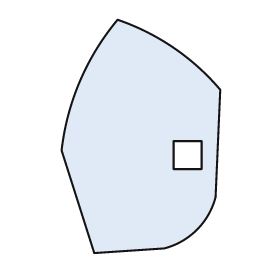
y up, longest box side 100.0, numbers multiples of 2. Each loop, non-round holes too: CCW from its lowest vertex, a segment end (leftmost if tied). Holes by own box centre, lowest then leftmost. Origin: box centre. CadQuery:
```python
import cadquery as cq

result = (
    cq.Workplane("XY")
    .moveTo(-20.0, -50.0)
    .lineTo(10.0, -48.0)
    .threePointArc((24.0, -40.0), (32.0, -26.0))
    .lineTo(34.0, 20.0)
    .threePointArc((14.0, 38.0), (-10.0, 50.0))
    .threePointArc((-26.0, 24.0), (-34.0, -6.0))
    .close()
    .moveTo(14.0, -14.0)
    .lineTo(26.0, -14.0)
    .lineTo(26.0, -2.0)
    .lineTo(14.0, -2.0)
    .close()
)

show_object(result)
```